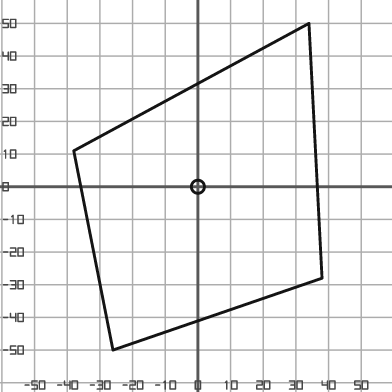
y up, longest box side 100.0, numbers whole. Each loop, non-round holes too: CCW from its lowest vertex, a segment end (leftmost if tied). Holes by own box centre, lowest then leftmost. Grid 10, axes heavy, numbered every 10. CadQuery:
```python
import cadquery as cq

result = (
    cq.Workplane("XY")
    .moveTo(-26.0, -50.0)
    .lineTo(38.0, -28.0)
    .lineTo(34.0, 50.0)
    .lineTo(-38.0, 11.0)
    .close()
    .moveTo(0.0, 0.0)
    .circle(2.0)
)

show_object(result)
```